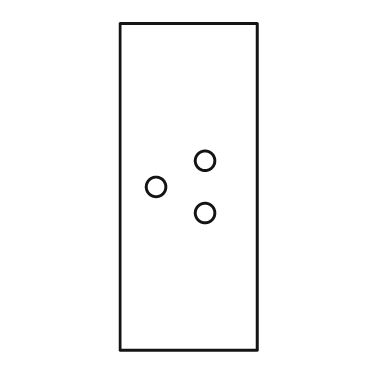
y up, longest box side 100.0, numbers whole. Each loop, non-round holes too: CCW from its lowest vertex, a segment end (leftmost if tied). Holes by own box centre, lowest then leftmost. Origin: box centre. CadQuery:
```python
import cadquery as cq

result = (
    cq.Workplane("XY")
    .moveTo(-21.0, -50.0)
    .lineTo(21.0, -50.0)
    .lineTo(21.0, 50.0)
    .lineTo(-21.0, 50.0)
    .close()
    .moveTo(5.0, -8.0)
    .circle(3.0)
    .moveTo(-10.0, 0.0)
    .circle(3.0)
    .moveTo(5.0, 8.0)
    .circle(3.0)
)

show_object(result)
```